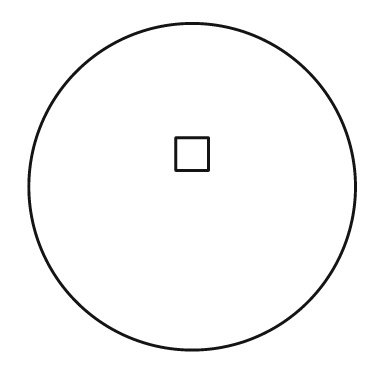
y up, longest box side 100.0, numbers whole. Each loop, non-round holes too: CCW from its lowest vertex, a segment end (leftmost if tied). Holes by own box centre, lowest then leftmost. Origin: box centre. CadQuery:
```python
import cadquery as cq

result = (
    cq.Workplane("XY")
    .moveTo(0.0, 0.0)
    .circle(50.0)
    .moveTo(-5.0, 5.0)
    .lineTo(5.0, 5.0)
    .lineTo(5.0, 15.0)
    .lineTo(-5.0, 15.0)
    .close()
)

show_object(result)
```